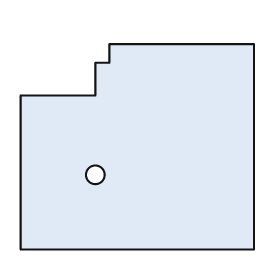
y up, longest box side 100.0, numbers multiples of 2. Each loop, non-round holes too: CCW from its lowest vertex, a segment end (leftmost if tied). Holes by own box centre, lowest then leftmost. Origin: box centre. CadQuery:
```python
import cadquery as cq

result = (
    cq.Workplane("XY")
    .moveTo(-50.0, -44.0)
    .lineTo(50.0, -44.0)
    .lineTo(50.0, 44.0)
    .lineTo(-12.0, 44.0)
    .lineTo(-12.0, 36.0)
    .lineTo(-18.0, 36.0)
    .lineTo(-18.0, 22.0)
    .lineTo(-50.0, 22.0)
    .close()
    .moveTo(-18.0, -12.0)
    .circle(4.0)
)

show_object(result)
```